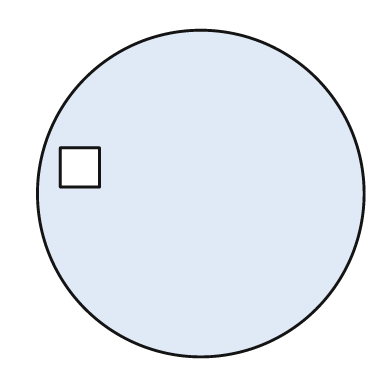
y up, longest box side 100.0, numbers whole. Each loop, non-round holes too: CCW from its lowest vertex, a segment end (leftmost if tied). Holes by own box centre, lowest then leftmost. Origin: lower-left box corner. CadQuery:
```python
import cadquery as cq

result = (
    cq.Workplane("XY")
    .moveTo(50.0, 50.0)
    .circle(50.0)
    .moveTo(7.0, 52.0)
    .lineTo(19.0, 52.0)
    .lineTo(19.0, 64.0)
    .lineTo(7.0, 64.0)
    .close()
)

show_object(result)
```